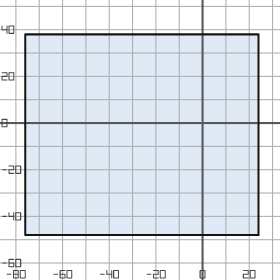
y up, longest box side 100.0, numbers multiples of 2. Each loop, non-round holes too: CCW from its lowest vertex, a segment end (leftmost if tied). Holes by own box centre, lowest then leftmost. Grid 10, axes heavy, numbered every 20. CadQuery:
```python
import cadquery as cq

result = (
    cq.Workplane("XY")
    .moveTo(-76.0, -48.0)
    .lineTo(24.0, -48.0)
    .lineTo(24.0, 38.0)
    .lineTo(-76.0, 38.0)
    .close()
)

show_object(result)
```